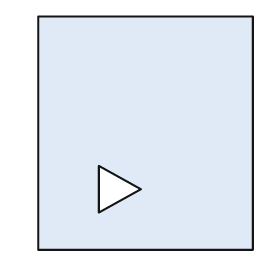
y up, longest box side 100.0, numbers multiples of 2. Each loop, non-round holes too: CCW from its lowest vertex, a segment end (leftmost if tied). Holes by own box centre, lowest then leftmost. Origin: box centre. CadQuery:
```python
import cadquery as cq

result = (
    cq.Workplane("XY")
    .moveTo(-46.0, -50.0)
    .lineTo(46.0, -50.0)
    .lineTo(46.0, 50.0)
    .lineTo(-46.0, 50.0)
    .close()
    .moveTo(-20.0, -34.0)
    .lineTo(-2.0, -24.0)
    .lineTo(-20.0, -14.0)
    .close()
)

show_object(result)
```